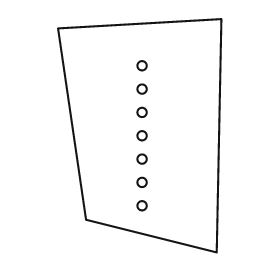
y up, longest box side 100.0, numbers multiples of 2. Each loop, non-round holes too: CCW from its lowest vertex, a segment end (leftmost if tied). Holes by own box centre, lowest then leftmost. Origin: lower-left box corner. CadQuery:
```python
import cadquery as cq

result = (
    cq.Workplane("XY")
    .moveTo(68.0, 0.0)
    .lineTo(70.0, 100.0)
    .lineTo(0.0, 96.0)
    .lineTo(12.0, 14.0)
    .close()
    .moveTo(36.0, 20.0)
    .circle(2.0)
    .moveTo(36.0, 30.0)
    .circle(2.0)
    .moveTo(36.0, 40.0)
    .circle(2.0)
    .moveTo(36.0, 50.0)
    .circle(2.0)
    .moveTo(36.0, 60.0)
    .circle(2.0)
    .moveTo(36.0, 70.0)
    .circle(2.0)
    .moveTo(36.0, 80.0)
    .circle(2.0)
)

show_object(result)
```